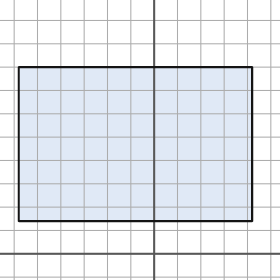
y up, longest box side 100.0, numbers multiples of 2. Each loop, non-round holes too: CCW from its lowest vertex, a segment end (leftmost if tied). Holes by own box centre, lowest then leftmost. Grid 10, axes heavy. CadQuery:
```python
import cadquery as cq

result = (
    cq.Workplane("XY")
    .moveTo(-58.0, 14.0)
    .lineTo(42.0, 14.0)
    .lineTo(42.0, 80.0)
    .lineTo(-58.0, 80.0)
    .close()
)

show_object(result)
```